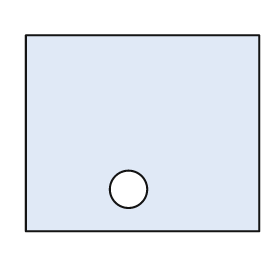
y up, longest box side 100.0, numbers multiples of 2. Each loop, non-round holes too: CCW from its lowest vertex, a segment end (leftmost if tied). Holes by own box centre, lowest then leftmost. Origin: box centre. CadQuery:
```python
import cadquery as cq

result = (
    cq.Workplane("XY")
    .moveTo(-50.0, -42.0)
    .lineTo(50.0, -42.0)
    .lineTo(50.0, 42.0)
    .lineTo(-50.0, 42.0)
    .close()
    .moveTo(-6.0, -24.0)
    .circle(8.0)
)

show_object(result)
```